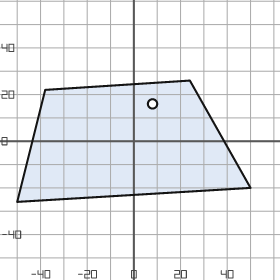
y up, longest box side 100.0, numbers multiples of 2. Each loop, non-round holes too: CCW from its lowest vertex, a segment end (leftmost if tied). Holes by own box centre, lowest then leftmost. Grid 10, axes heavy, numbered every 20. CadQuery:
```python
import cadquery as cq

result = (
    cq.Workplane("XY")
    .moveTo(-50.0, -26.0)
    .lineTo(50.0, -20.0)
    .lineTo(24.0, 26.0)
    .lineTo(-38.0, 22.0)
    .close()
    .moveTo(8.0, 16.0)
    .circle(2.0)
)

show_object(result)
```